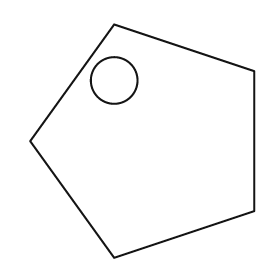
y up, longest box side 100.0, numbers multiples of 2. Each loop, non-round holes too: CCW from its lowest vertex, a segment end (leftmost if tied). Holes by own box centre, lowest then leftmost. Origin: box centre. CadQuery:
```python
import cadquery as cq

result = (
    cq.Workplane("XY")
    .moveTo(-12.0, -50.0)
    .lineTo(48.0, -30.0)
    .lineTo(48.0, 30.0)
    .lineTo(-12.0, 50.0)
    .lineTo(-48.0, 0.0)
    .close()
    .moveTo(-12.0, 26.0)
    .circle(10.0)
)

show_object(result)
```